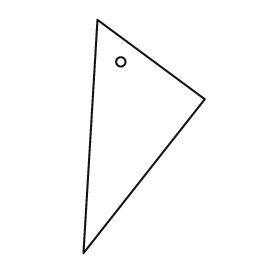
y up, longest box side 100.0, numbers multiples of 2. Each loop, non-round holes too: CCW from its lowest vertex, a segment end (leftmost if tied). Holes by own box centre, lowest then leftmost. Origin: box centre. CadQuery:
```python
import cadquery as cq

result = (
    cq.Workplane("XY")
    .moveTo(-26.0, -50.0)
    .lineTo(26.0, 16.0)
    .lineTo(-20.0, 50.0)
    .close()
    .moveTo(-10.0, 32.0)
    .circle(2.0)
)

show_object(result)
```